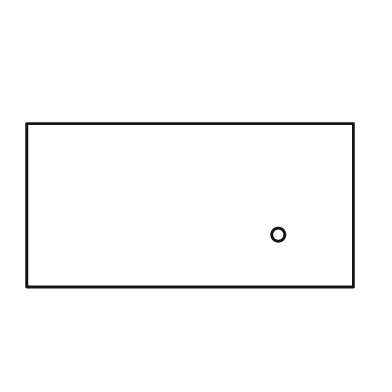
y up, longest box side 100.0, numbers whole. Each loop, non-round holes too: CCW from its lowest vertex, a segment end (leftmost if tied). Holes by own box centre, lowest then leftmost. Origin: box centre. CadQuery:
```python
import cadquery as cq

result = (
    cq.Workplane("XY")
    .moveTo(-50.0, -25.0)
    .lineTo(50.0, -25.0)
    .lineTo(50.0, 25.0)
    .lineTo(-50.0, 25.0)
    .close()
    .moveTo(27.0, -9.0)
    .circle(2.0)
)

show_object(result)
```